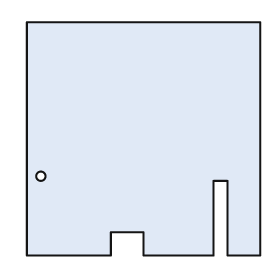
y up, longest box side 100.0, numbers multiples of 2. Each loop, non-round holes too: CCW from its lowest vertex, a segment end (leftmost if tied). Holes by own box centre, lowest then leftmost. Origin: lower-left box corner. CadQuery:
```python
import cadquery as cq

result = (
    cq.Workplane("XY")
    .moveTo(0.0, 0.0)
    .lineTo(36.0, 0.0)
    .lineTo(36.0, 10.0)
    .lineTo(50.0, 10.0)
    .lineTo(50.0, 0.0)
    .lineTo(80.0, 0.0)
    .lineTo(80.0, 32.0)
    .lineTo(86.0, 32.0)
    .lineTo(86.0, 0.0)
    .lineTo(100.0, 0.0)
    .lineTo(100.0, 100.0)
    .lineTo(0.0, 100.0)
    .close()
    .moveTo(6.0, 34.0)
    .circle(2.0)
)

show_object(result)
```